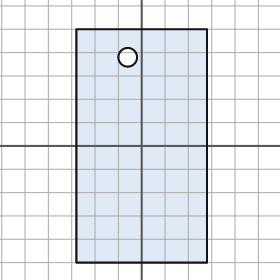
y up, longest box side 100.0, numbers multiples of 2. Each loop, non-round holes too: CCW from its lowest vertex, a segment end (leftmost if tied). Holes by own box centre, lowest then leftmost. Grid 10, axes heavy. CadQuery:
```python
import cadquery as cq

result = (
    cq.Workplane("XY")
    .moveTo(-28.0, -50.0)
    .lineTo(28.0, -50.0)
    .lineTo(28.0, 50.0)
    .lineTo(-28.0, 50.0)
    .close()
    .moveTo(-6.0, 38.0)
    .circle(4.0)
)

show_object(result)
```